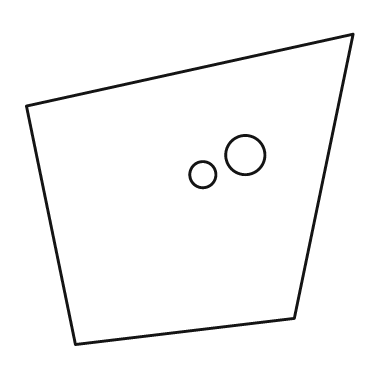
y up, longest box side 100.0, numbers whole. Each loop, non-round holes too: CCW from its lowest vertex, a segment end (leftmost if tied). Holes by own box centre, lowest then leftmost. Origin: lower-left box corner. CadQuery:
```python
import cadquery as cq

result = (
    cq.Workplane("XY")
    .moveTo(15.0, 0.0)
    .lineTo(82.0, 8.0)
    .lineTo(100.0, 95.0)
    .lineTo(0.0, 73.0)
    .close()
    .moveTo(54.0, 52.0)
    .circle(4.0)
    .moveTo(67.0, 58.0)
    .circle(6.0)
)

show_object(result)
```